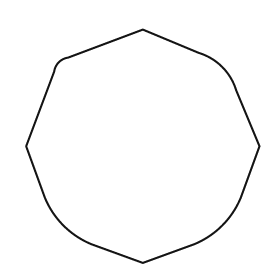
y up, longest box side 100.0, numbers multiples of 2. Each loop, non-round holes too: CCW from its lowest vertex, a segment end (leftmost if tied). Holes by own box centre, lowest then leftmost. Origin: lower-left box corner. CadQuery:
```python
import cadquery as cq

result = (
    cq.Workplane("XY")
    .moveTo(50.0, 0.0)
    .lineTo(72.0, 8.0)
    .threePointArc((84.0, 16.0), (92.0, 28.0))
    .lineTo(100.0, 50.0)
    .lineTo(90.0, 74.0)
    .threePointArc((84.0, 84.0), (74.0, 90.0))
    .lineTo(50.0, 100.0)
    .lineTo(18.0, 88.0)
    .threePointArc((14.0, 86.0), (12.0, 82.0))
    .lineTo(0.0, 50.0)
    .lineTo(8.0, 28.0)
    .threePointArc((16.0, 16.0), (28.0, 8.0))
    .close()
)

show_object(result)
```